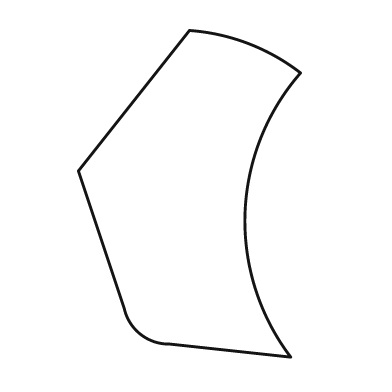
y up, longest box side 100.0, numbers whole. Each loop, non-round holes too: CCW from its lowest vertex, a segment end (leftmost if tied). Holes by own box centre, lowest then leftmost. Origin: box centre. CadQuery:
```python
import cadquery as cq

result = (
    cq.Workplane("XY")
    .moveTo(31.0, -50.0)
    .threePointArc((17.0, -6.0), (34.0, 37.0))
    .threePointArc((18.0, 46.0), (0.0, 50.0))
    .lineTo(-34.0, 7.0)
    .lineTo(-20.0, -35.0)
    .threePointArc((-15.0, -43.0), (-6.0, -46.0))
    .close()
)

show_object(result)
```